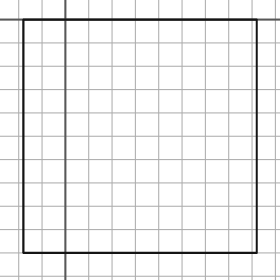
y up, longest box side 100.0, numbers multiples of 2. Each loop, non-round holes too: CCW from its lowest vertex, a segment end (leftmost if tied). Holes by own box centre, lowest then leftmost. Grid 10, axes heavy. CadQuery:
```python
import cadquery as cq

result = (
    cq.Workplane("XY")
    .moveTo(-18.0, -100.0)
    .lineTo(82.0, -100.0)
    .lineTo(82.0, 0.0)
    .lineTo(-18.0, 0.0)
    .close()
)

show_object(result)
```